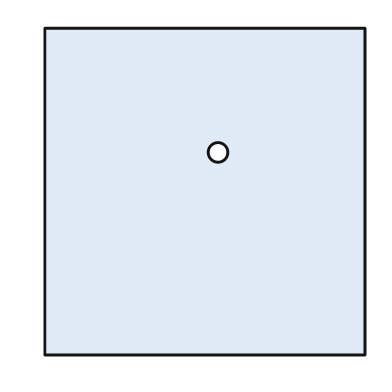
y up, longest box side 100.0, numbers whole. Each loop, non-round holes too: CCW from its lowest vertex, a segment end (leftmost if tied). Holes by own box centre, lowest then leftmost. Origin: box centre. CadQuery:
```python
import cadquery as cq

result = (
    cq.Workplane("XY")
    .moveTo(-49.0, -50.0)
    .lineTo(49.0, -50.0)
    .lineTo(49.0, 50.0)
    .lineTo(-49.0, 50.0)
    .close()
    .moveTo(4.0, 12.0)
    .circle(3.0)
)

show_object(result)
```